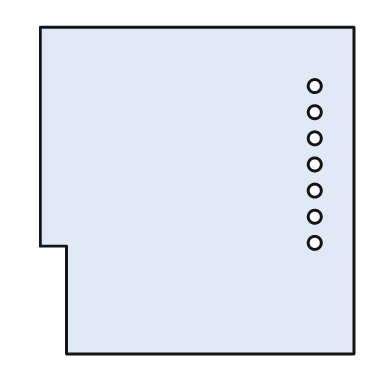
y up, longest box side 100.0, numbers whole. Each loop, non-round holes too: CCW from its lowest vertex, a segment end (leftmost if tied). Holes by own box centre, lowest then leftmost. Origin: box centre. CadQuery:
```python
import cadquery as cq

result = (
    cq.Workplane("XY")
    .moveTo(-40.0, -50.0)
    .lineTo(48.0, -50.0)
    .lineTo(48.0, 50.0)
    .lineTo(-48.0, 50.0)
    .lineTo(-48.0, -17.0)
    .lineTo(-40.0, -17.0)
    .close()
    .moveTo(36.0, -16.0)
    .circle(2.0)
    .moveTo(36.0, -8.0)
    .circle(2.0)
    .moveTo(36.0, 0.0)
    .circle(2.0)
    .moveTo(36.0, 8.0)
    .circle(2.0)
    .moveTo(36.0, 16.0)
    .circle(2.0)
    .moveTo(36.0, 24.0)
    .circle(2.0)
    .moveTo(36.0, 32.0)
    .circle(2.0)
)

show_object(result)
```